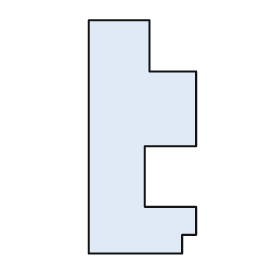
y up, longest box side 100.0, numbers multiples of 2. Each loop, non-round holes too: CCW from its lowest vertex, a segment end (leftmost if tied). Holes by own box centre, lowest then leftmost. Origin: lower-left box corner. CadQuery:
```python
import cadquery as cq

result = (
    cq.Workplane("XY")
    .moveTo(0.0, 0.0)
    .lineTo(40.0, 0.0)
    .lineTo(40.0, 8.0)
    .lineTo(46.0, 8.0)
    .lineTo(46.0, 20.0)
    .lineTo(24.0, 20.0)
    .lineTo(24.0, 46.0)
    .lineTo(46.0, 46.0)
    .lineTo(46.0, 78.0)
    .lineTo(26.0, 78.0)
    .lineTo(26.0, 100.0)
    .lineTo(0.0, 100.0)
    .close()
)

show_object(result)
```